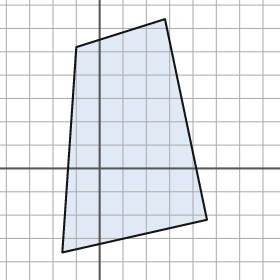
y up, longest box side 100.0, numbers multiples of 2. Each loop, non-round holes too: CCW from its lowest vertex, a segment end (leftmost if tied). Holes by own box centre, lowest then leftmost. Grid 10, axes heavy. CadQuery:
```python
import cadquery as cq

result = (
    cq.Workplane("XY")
    .moveTo(-16.0, -36.0)
    .lineTo(46.0, -22.0)
    .lineTo(28.0, 64.0)
    .lineTo(-10.0, 52.0)
    .close()
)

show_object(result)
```